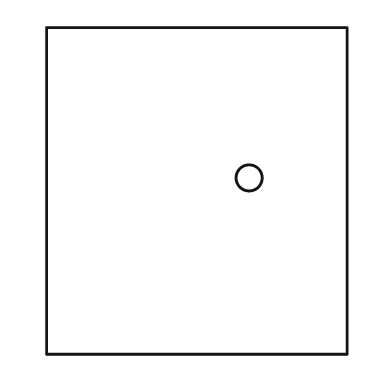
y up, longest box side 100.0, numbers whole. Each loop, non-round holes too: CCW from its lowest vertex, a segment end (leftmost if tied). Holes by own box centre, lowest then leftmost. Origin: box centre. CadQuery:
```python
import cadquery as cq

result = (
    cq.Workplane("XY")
    .moveTo(-46.0, -50.0)
    .lineTo(46.0, -50.0)
    .lineTo(46.0, 50.0)
    .lineTo(-46.0, 50.0)
    .close()
    .moveTo(16.0, 4.0)
    .circle(4.0)
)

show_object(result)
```